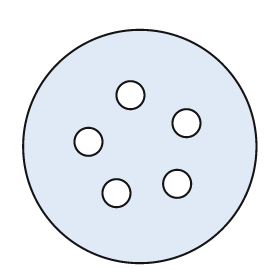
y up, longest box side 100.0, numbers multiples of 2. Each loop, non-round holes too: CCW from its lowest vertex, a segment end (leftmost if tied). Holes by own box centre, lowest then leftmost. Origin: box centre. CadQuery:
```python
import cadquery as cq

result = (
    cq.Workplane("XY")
    .moveTo(0.0, 0.0)
    .circle(50.0)
    .moveTo(-10.0, -20.0)
    .circle(6.0)
    .moveTo(16.0, -16.0)
    .circle(6.0)
    .moveTo(-22.0, 2.0)
    .circle(6.0)
    .moveTo(20.0, 10.0)
    .circle(6.0)
    .moveTo(-4.0, 22.0)
    .circle(6.0)
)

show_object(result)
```